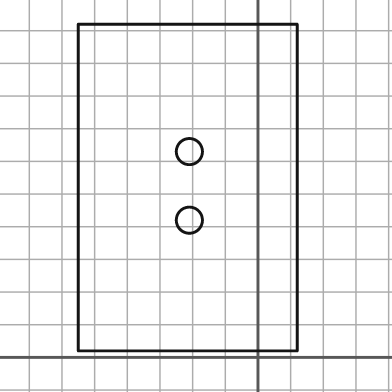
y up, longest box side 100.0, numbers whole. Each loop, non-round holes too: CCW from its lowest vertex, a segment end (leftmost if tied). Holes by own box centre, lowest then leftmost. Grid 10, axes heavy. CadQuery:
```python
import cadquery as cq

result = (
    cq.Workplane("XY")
    .moveTo(-55.0, 2.0)
    .lineTo(12.0, 2.0)
    .lineTo(12.0, 102.0)
    .lineTo(-55.0, 102.0)
    .close()
    .moveTo(-21.0, 42.0)
    .circle(4.0)
    .moveTo(-21.0, 63.0)
    .circle(4.0)
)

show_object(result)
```